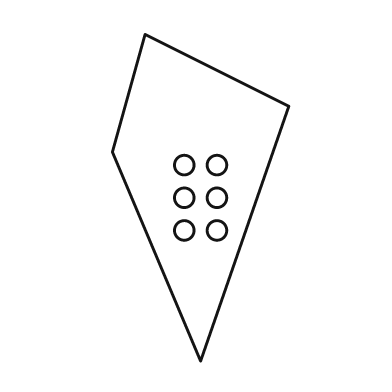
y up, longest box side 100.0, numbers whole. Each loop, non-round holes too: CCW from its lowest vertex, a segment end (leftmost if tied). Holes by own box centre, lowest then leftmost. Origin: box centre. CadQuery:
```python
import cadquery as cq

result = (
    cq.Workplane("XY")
    .moveTo(0.0, -50.0)
    .lineTo(27.0, 28.0)
    .lineTo(-17.0, 50.0)
    .lineTo(-27.0, 14.0)
    .close()
    .moveTo(-5.0, -10.0)
    .circle(3.0)
    .moveTo(5.0, -10.0)
    .circle(3.0)
    .moveTo(-5.0, 0.0)
    .circle(3.0)
    .moveTo(5.0, 0.0)
    .circle(3.0)
    .moveTo(-5.0, 10.0)
    .circle(3.0)
    .moveTo(5.0, 10.0)
    .circle(3.0)
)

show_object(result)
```